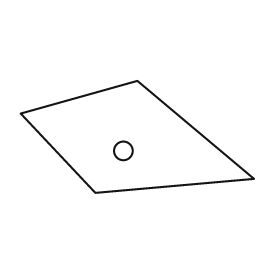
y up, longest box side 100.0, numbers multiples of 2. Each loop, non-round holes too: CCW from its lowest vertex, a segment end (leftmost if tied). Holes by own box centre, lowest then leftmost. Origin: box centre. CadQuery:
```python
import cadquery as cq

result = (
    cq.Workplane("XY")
    .moveTo(-18.0, -24.0)
    .lineTo(50.0, -18.0)
    .lineTo(0.0, 24.0)
    .lineTo(-50.0, 10.0)
    .close()
    .moveTo(-6.0, -6.0)
    .circle(4.0)
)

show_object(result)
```